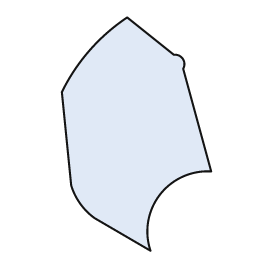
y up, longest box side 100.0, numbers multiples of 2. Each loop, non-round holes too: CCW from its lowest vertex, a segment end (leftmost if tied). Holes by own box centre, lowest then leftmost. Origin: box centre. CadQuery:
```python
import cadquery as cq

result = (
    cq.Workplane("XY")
    .moveTo(6.0, -50.0)
    .threePointArc((10.0, -26.0), (32.0, -16.0))
    .lineTo(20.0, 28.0)
    .threePointArc((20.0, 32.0), (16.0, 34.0))
    .lineTo(-4.0, 50.0)
    .threePointArc((-20.0, 36.0), (-32.0, 18.0))
    .lineTo(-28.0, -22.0)
    .threePointArc((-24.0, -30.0), (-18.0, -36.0))
    .close()
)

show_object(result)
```